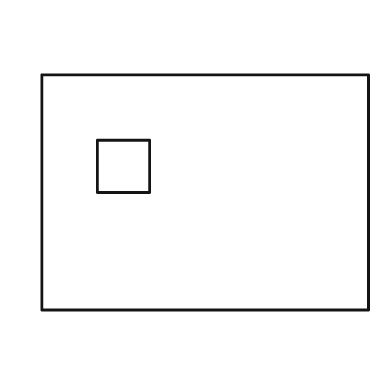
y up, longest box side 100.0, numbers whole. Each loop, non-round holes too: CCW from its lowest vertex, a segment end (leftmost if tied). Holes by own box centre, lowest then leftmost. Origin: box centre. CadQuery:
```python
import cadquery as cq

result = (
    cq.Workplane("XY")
    .moveTo(-50.0, -36.0)
    .lineTo(50.0, -36.0)
    .lineTo(50.0, 36.0)
    .lineTo(-50.0, 36.0)
    .close()
    .moveTo(-33.0, 0.0)
    .lineTo(-17.0, 0.0)
    .lineTo(-17.0, 16.0)
    .lineTo(-33.0, 16.0)
    .close()
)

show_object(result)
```